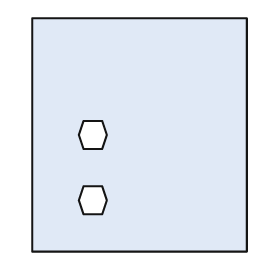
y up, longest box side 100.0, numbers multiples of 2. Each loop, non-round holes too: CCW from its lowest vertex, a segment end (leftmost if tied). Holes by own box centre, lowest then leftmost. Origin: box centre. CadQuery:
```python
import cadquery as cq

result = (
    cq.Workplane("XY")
    .moveTo(-46.0, -50.0)
    .lineTo(46.0, -50.0)
    .lineTo(46.0, 50.0)
    .lineTo(-46.0, 50.0)
    .close()
    .moveTo(-24.0, -34.0)
    .lineTo(-16.0, -34.0)
    .lineTo(-14.0, -28.0)
    .lineTo(-16.0, -22.0)
    .lineTo(-24.0, -22.0)
    .lineTo(-26.0, -28.0)
    .close()
    .moveTo(-24.0, -6.0)
    .lineTo(-16.0, -6.0)
    .lineTo(-14.0, 0.0)
    .lineTo(-16.0, 6.0)
    .lineTo(-24.0, 6.0)
    .lineTo(-26.0, 0.0)
    .close()
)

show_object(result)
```